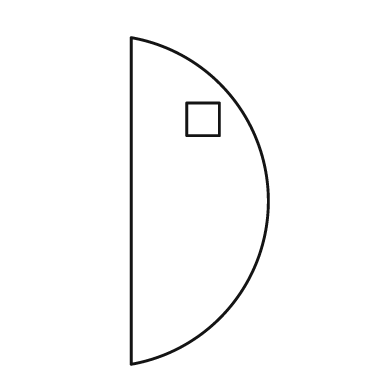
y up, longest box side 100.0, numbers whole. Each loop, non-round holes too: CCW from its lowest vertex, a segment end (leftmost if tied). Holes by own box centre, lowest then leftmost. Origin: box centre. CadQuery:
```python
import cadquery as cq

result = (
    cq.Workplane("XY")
    .moveTo(-21.0, -50.0)
    .threePointArc((21.0, 0.0), (-21.0, 50.0))
    .close()
    .moveTo(-4.0, 20.0)
    .lineTo(6.0, 20.0)
    .lineTo(6.0, 30.0)
    .lineTo(-4.0, 30.0)
    .close()
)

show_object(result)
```